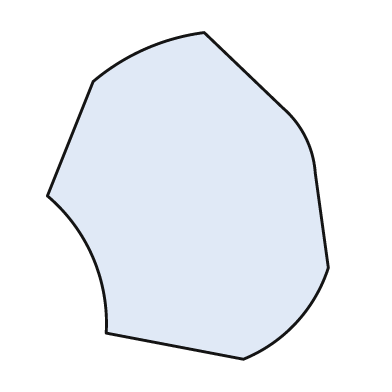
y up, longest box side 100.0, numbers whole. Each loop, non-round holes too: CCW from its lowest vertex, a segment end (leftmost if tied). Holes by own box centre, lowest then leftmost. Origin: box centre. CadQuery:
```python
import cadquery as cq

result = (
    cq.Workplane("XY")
    .moveTo(17.0, -50.0)
    .threePointArc((33.0, -39.0), (43.0, -22.0))
    .lineTo(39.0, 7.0)
    .threePointArc((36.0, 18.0), (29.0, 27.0))
    .lineTo(5.0, 50.0)
    .threePointArc((-13.0, 45.0), (-29.0, 35.0))
    .lineTo(-43.0, 0.0)
    .threePointArc((-29.0, -19.0), (-25.0, -42.0))
    .close()
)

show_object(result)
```